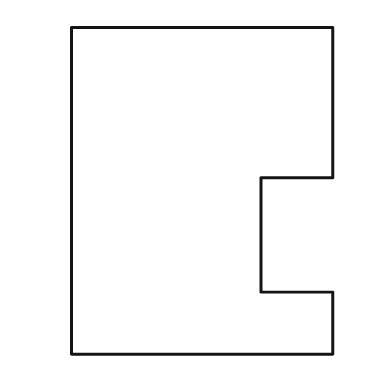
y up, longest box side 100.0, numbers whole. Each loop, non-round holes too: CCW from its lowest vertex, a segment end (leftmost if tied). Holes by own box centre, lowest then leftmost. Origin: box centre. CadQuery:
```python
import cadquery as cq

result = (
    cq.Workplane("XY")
    .moveTo(-40.0, -50.0)
    .lineTo(40.0, -50.0)
    .lineTo(40.0, -31.0)
    .lineTo(18.0, -31.0)
    .lineTo(18.0, 4.0)
    .lineTo(40.0, 4.0)
    .lineTo(40.0, 50.0)
    .lineTo(-40.0, 50.0)
    .close()
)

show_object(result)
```